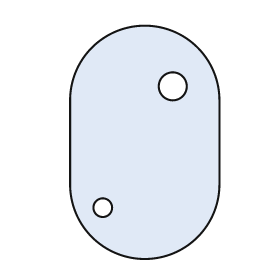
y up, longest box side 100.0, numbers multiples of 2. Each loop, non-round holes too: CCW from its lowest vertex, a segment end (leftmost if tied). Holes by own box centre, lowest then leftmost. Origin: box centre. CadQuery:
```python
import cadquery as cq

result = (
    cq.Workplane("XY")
    .moveTo(-32.0, -18.0)
    .threePointArc((0.0, -50.0), (32.0, -18.0))
    .lineTo(32.0, 18.0)
    .threePointArc((0.0, 50.0), (-32.0, 18.0))
    .close()
    .moveTo(-18.0, -28.0)
    .circle(4.0)
    .moveTo(12.0, 24.0)
    .circle(6.0)
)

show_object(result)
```